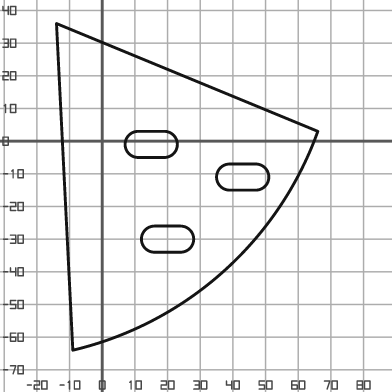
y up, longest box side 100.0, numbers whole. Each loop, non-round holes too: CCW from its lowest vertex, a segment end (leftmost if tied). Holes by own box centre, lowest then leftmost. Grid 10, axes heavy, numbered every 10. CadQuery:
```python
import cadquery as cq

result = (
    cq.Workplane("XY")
    .moveTo(-9.0, -64.0)
    .threePointArc((37.0, -40.0), (66.0, 3.0))
    .lineTo(-14.0, 36.0)
    .close()
    .moveTo(16.0, -34.0)
    .lineTo(24.0, -34.0)
    .threePointArc((28.0, -30.0), (24.0, -26.0))
    .lineTo(16.0, -26.0)
    .threePointArc((12.0, -30.0), (16.0, -34.0))
    .close()
    .moveTo(39.0, -15.0)
    .lineTo(47.0, -15.0)
    .threePointArc((51.0, -11.0), (47.0, -7.0))
    .lineTo(39.0, -7.0)
    .threePointArc((35.0, -11.0), (39.0, -15.0))
    .close()
    .moveTo(11.0, -5.0)
    .lineTo(19.0, -5.0)
    .threePointArc((23.0, -1.0), (19.0, 3.0))
    .lineTo(11.0, 3.0)
    .threePointArc((7.0, -1.0), (11.0, -5.0))
    .close()
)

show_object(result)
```